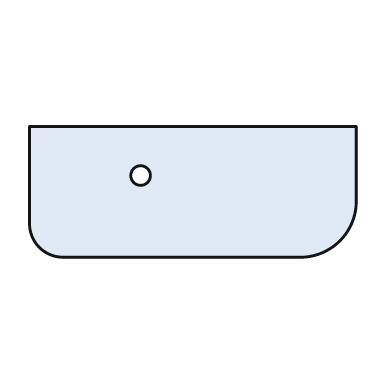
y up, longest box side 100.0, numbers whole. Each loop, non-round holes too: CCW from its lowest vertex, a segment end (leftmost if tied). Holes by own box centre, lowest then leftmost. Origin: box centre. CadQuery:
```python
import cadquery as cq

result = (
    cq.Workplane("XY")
    .moveTo(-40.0, -20.0)
    .lineTo(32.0, -20.0)
    .threePointArc((45.0, -15.0), (50.0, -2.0))
    .lineTo(50.0, 20.0)
    .lineTo(-50.0, 20.0)
    .lineTo(-50.0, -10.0)
    .threePointArc((-47.0, -17.0), (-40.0, -20.0))
    .close()
    .moveTo(-16.0, 5.0)
    .circle(3.0)
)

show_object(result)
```